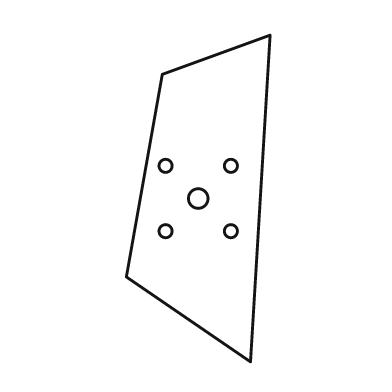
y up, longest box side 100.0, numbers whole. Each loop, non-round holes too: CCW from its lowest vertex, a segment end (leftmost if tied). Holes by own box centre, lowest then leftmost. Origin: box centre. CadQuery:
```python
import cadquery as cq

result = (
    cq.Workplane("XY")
    .moveTo(16.0, -50.0)
    .lineTo(22.0, 50.0)
    .lineTo(-11.0, 38.0)
    .lineTo(-22.0, -24.0)
    .close()
    .moveTo(-10.0, -10.0)
    .circle(2.0)
    .moveTo(10.0, -10.0)
    .circle(2.0)
    .moveTo(0.0, 0.0)
    .circle(3.0)
    .moveTo(-10.0, 10.0)
    .circle(2.0)
    .moveTo(10.0, 10.0)
    .circle(2.0)
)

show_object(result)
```